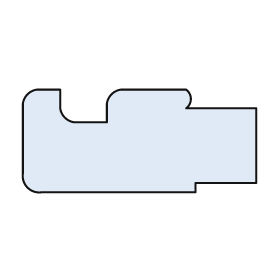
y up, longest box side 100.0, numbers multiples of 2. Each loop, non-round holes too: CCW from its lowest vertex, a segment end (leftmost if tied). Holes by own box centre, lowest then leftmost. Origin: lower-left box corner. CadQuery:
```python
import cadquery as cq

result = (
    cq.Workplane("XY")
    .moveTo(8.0, 0.0)
    .lineTo(74.0, 0.0)
    .lineTo(74.0, 4.0)
    .lineTo(100.0, 4.0)
    .lineTo(100.0, 36.0)
    .lineTo(70.0, 36.0)
    .threePointArc((72.0, 40.0), (70.0, 44.0))
    .lineTo(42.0, 44.0)
    .threePointArc((38.0, 42.0), (36.0, 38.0))
    .lineTo(36.0, 30.0)
    .lineTo(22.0, 30.0)
    .threePointArc((18.0, 32.0), (16.0, 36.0))
    .lineTo(16.0, 44.0)
    .lineTo(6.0, 44.0)
    .threePointArc((2.0, 42.0), (0.0, 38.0))
    .lineTo(0.0, 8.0)
    .threePointArc((2.0, 2.0), (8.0, 0.0))
    .close()
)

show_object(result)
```